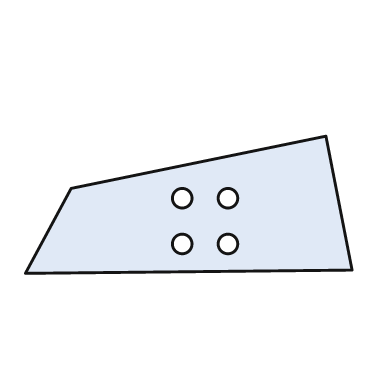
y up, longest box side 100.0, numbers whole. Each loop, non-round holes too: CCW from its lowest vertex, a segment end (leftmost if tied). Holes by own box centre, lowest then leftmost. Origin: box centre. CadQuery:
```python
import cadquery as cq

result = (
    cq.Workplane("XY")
    .moveTo(-50.0, -21.0)
    .lineTo(50.0, -20.0)
    .lineTo(42.0, 21.0)
    .lineTo(-36.0, 5.0)
    .close()
    .moveTo(-2.0, -12.0)
    .circle(3.0)
    .moveTo(12.0, -12.0)
    .circle(3.0)
    .moveTo(-2.0, 2.0)
    .circle(3.0)
    .moveTo(12.0, 2.0)
    .circle(3.0)
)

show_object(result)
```